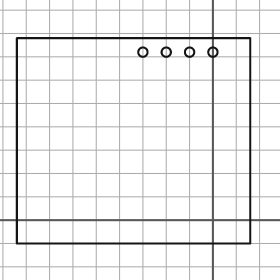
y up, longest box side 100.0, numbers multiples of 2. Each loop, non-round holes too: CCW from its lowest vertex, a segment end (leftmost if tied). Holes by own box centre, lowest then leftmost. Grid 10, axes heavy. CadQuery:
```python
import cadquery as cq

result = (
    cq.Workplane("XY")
    .moveTo(-84.0, -10.0)
    .lineTo(16.0, -10.0)
    .lineTo(16.0, 78.0)
    .lineTo(-84.0, 78.0)
    .close()
    .moveTo(-30.0, 72.0)
    .circle(2.0)
    .moveTo(-20.0, 72.0)
    .circle(2.0)
    .moveTo(-10.0, 72.0)
    .circle(2.0)
    .moveTo(0.0, 72.0)
    .circle(2.0)
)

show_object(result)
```